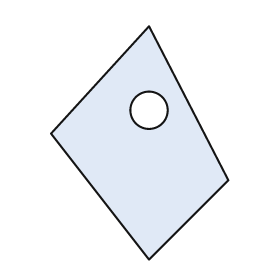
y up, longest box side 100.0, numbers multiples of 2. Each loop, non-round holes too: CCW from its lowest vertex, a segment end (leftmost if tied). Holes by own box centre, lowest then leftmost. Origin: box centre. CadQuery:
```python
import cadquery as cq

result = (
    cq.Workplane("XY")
    .moveTo(4.0, -50.0)
    .lineTo(38.0, -16.0)
    .lineTo(4.0, 50.0)
    .lineTo(-38.0, 4.0)
    .close()
    .moveTo(4.0, 14.0)
    .circle(8.0)
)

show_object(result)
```